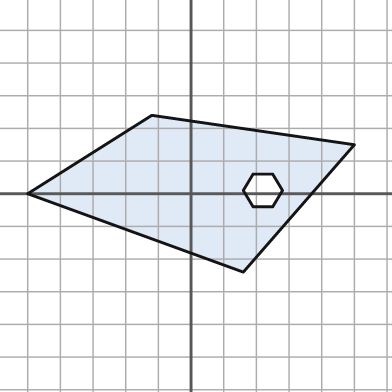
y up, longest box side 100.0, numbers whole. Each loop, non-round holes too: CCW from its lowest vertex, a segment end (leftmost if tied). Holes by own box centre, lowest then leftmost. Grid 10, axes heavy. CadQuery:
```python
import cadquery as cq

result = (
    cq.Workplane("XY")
    .moveTo(16.0, -24.0)
    .lineTo(50.0, 15.0)
    .lineTo(-12.0, 24.0)
    .lineTo(-50.0, 0.0)
    .close()
    .moveTo(19.0, -4.0)
    .lineTo(25.0, -4.0)
    .lineTo(28.0, 1.0)
    .lineTo(25.0, 6.0)
    .lineTo(19.0, 6.0)
    .lineTo(16.0, 1.0)
    .close()
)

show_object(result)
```